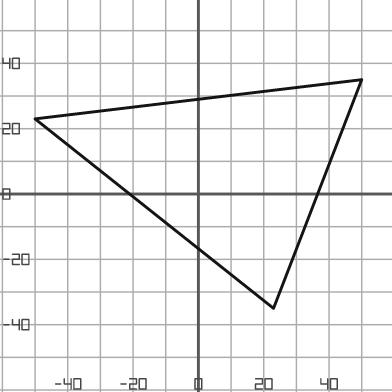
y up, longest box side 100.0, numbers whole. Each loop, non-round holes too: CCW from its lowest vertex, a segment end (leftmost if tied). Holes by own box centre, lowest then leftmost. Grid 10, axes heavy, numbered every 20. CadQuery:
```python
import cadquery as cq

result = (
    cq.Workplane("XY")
    .moveTo(23.0, -35.0)
    .lineTo(50.0, 35.0)
    .lineTo(-50.0, 23.0)
    .close()
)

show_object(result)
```